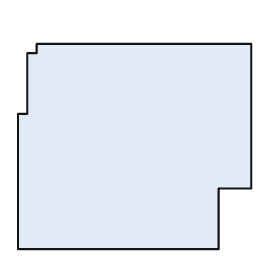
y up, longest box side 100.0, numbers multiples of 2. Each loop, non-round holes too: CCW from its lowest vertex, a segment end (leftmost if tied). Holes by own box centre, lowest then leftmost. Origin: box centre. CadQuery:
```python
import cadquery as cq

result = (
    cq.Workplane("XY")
    .moveTo(-50.0, -44.0)
    .lineTo(36.0, -44.0)
    .lineTo(36.0, -18.0)
    .lineTo(50.0, -18.0)
    .lineTo(50.0, 44.0)
    .lineTo(-42.0, 44.0)
    .lineTo(-42.0, 40.0)
    .lineTo(-46.0, 40.0)
    .lineTo(-46.0, 14.0)
    .lineTo(-50.0, 14.0)
    .close()
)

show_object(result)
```